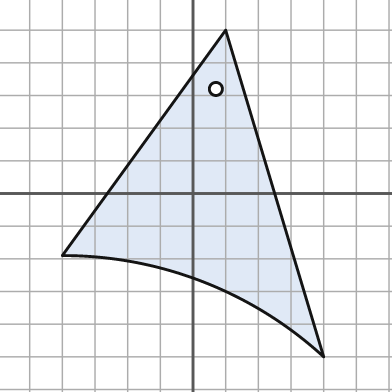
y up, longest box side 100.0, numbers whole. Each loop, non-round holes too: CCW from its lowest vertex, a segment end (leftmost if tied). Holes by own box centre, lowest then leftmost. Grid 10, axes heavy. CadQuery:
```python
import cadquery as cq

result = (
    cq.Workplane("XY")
    .moveTo(40.0, -50.0)
    .lineTo(10.0, 50.0)
    .lineTo(-40.0, -19.0)
    .threePointArc((3.0, -27.0), (40.0, -50.0))
    .close()
    .moveTo(7.0, 32.0)
    .circle(2.0)
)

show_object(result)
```